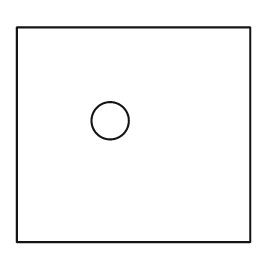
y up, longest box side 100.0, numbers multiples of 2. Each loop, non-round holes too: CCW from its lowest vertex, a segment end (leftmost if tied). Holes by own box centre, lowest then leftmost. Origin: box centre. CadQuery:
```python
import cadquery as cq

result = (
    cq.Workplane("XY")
    .moveTo(-50.0, -46.0)
    .lineTo(50.0, -46.0)
    .lineTo(50.0, 46.0)
    .lineTo(-50.0, 46.0)
    .close()
    .moveTo(-10.0, 6.0)
    .circle(8.0)
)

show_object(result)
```